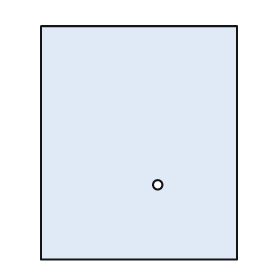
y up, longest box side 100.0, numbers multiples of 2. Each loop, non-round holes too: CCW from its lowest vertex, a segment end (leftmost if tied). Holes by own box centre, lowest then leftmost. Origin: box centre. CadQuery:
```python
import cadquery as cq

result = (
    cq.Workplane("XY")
    .moveTo(-42.0, -50.0)
    .lineTo(42.0, -50.0)
    .lineTo(42.0, 50.0)
    .lineTo(-42.0, 50.0)
    .close()
    .moveTo(8.0, -18.0)
    .circle(2.0)
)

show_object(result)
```